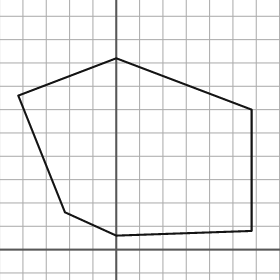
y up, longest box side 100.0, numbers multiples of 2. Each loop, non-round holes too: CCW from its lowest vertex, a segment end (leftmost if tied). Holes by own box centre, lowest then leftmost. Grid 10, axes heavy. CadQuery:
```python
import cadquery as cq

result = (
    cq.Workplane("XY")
    .moveTo(0.0, 6.0)
    .lineTo(58.0, 8.0)
    .lineTo(58.0, 60.0)
    .lineTo(0.0, 82.0)
    .lineTo(-42.0, 66.0)
    .lineTo(-22.0, 16.0)
    .close()
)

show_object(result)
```